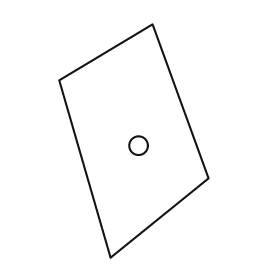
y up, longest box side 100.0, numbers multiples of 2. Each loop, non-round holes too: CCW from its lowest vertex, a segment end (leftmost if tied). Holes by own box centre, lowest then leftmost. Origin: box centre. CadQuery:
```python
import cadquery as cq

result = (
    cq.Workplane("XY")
    .moveTo(-10.0, -50.0)
    .lineTo(32.0, -16.0)
    .lineTo(8.0, 50.0)
    .lineTo(-32.0, 26.0)
    .close()
    .moveTo(2.0, -2.0)
    .circle(4.0)
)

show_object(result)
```